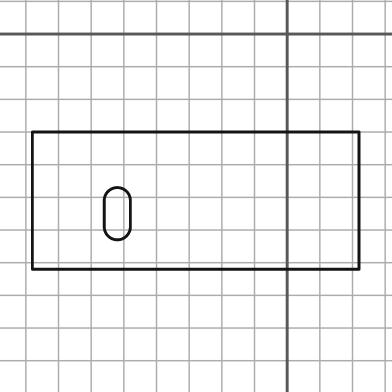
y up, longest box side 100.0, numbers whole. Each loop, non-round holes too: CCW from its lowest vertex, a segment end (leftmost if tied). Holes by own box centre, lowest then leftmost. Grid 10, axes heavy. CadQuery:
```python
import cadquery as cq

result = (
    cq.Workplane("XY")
    .moveTo(-78.0, -72.0)
    .lineTo(22.0, -72.0)
    .lineTo(22.0, -30.0)
    .lineTo(-78.0, -30.0)
    .close()
    .moveTo(-56.0, -59.0)
    .threePointArc((-52.0, -63.0), (-48.0, -59.0))
    .lineTo(-48.0, -51.0)
    .threePointArc((-52.0, -47.0), (-56.0, -51.0))
    .close()
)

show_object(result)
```